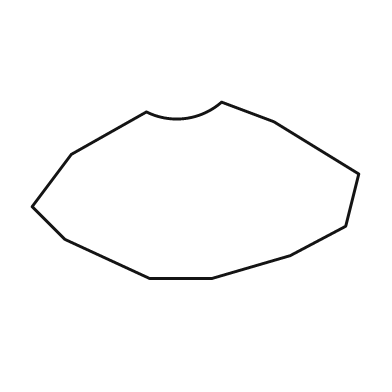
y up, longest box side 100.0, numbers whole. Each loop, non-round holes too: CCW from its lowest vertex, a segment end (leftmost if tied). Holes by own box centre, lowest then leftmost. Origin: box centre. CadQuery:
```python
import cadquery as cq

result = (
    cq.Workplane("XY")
    .moveTo(-14.0, -27.0)
    .lineTo(5.0, -27.0)
    .lineTo(29.0, -20.0)
    .lineTo(46.0, -11.0)
    .lineTo(50.0, 5.0)
    .lineTo(24.0, 21.0)
    .lineTo(8.0, 27.0)
    .threePointArc((-3.0, 22.0), (-15.0, 24.0))
    .lineTo(-38.0, 11.0)
    .lineTo(-50.0, -5.0)
    .lineTo(-40.0, -15.0)
    .close()
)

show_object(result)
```